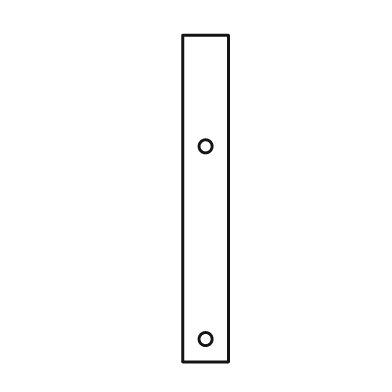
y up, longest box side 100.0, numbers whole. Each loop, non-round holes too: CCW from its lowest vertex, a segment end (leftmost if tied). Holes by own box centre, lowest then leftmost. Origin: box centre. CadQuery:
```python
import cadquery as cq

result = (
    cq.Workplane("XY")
    .moveTo(-7.0, -50.0)
    .lineTo(7.0, -50.0)
    .lineTo(7.0, 50.0)
    .lineTo(-7.0, 50.0)
    .close()
    .moveTo(0.0, -43.0)
    .circle(2.0)
    .moveTo(0.0, 16.0)
    .circle(2.0)
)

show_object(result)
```